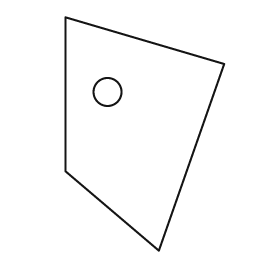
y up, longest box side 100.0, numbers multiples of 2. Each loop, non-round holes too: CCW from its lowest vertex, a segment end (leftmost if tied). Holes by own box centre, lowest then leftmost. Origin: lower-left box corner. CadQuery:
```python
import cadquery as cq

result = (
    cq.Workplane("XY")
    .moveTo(40.0, 0.0)
    .lineTo(68.0, 80.0)
    .lineTo(0.0, 100.0)
    .lineTo(0.0, 34.0)
    .close()
    .moveTo(18.0, 68.0)
    .circle(6.0)
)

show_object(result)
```